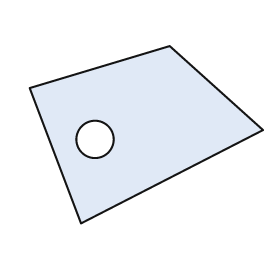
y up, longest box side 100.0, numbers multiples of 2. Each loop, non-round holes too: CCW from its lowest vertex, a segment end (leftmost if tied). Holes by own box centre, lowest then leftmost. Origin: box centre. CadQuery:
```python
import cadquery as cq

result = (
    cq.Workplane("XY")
    .moveTo(-28.0, -38.0)
    .lineTo(50.0, 2.0)
    .lineTo(10.0, 38.0)
    .lineTo(-50.0, 20.0)
    .close()
    .moveTo(-22.0, -2.0)
    .circle(8.0)
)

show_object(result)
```